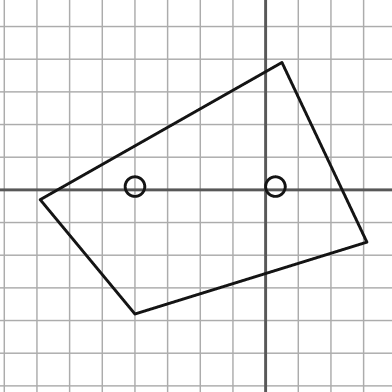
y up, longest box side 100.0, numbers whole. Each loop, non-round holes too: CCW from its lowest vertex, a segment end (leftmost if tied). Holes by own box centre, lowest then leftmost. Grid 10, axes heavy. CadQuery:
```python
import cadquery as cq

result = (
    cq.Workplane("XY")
    .moveTo(-40.0, -38.0)
    .lineTo(31.0, -16.0)
    .lineTo(5.0, 39.0)
    .lineTo(-69.0, -3.0)
    .close()
    .moveTo(-40.0, 1.0)
    .circle(3.0)
    .moveTo(3.0, 1.0)
    .circle(3.0)
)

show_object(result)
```